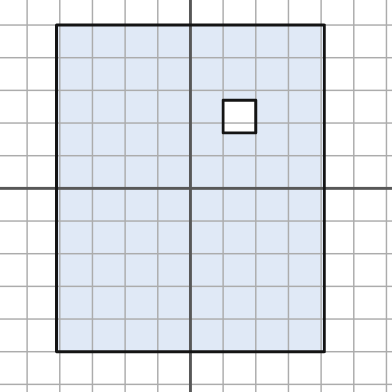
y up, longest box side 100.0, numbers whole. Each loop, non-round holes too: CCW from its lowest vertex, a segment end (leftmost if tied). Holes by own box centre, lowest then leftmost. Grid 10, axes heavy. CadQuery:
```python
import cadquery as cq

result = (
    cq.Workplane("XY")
    .moveTo(-41.0, -50.0)
    .lineTo(41.0, -50.0)
    .lineTo(41.0, 50.0)
    .lineTo(-41.0, 50.0)
    .close()
    .moveTo(10.0, 17.0)
    .lineTo(20.0, 17.0)
    .lineTo(20.0, 27.0)
    .lineTo(10.0, 27.0)
    .close()
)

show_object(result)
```